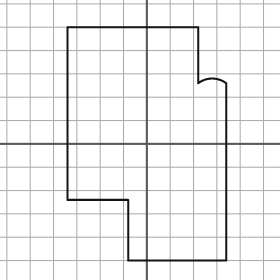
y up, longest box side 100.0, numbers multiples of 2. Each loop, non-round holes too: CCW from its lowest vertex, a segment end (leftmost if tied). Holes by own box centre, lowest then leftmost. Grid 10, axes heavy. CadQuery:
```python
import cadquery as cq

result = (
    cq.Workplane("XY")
    .moveTo(-8.0, -50.0)
    .lineTo(34.0, -50.0)
    .lineTo(34.0, 26.0)
    .threePointArc((28.0, 28.0), (22.0, 26.0))
    .lineTo(22.0, 50.0)
    .lineTo(-34.0, 50.0)
    .lineTo(-34.0, -24.0)
    .lineTo(-8.0, -24.0)
    .close()
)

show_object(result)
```